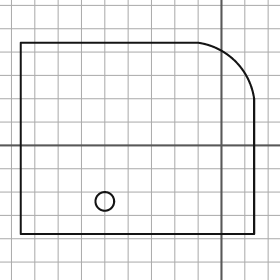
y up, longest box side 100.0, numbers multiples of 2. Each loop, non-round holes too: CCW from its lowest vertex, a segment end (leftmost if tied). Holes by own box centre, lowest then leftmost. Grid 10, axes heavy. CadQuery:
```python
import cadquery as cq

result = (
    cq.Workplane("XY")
    .moveTo(-86.0, -38.0)
    .lineTo(14.0, -38.0)
    .lineTo(14.0, 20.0)
    .threePointArc((6.0, 36.0), (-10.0, 44.0))
    .lineTo(-86.0, 44.0)
    .close()
    .moveTo(-50.0, -24.0)
    .circle(4.0)
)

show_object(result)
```